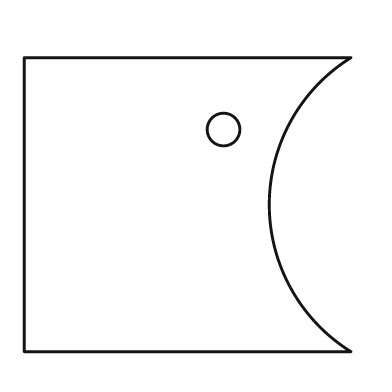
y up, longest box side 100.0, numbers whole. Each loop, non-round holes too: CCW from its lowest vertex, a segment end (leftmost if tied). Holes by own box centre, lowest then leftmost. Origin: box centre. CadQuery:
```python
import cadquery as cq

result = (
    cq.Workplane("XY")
    .moveTo(-50.0, -45.0)
    .lineTo(50.0, -45.0)
    .threePointArc((25.0, 0.0), (50.0, 45.0))
    .lineTo(-50.0, 45.0)
    .close()
    .moveTo(11.0, 23.0)
    .circle(5.0)
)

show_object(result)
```